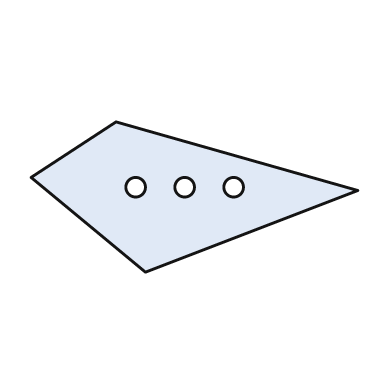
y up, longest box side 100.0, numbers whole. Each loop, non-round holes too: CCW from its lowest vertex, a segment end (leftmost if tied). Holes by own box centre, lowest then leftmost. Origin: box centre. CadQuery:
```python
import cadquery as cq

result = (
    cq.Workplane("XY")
    .moveTo(-15.0, -23.0)
    .lineTo(50.0, 2.0)
    .lineTo(-24.0, 23.0)
    .lineTo(-50.0, 6.0)
    .close()
    .moveTo(-18.0, 3.0)
    .circle(3.0)
    .moveTo(-3.0, 3.0)
    .circle(3.0)
    .moveTo(12.0, 3.0)
    .circle(3.0)
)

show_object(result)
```